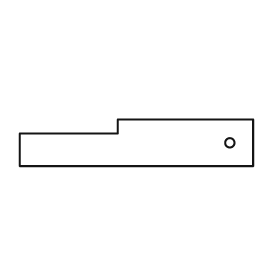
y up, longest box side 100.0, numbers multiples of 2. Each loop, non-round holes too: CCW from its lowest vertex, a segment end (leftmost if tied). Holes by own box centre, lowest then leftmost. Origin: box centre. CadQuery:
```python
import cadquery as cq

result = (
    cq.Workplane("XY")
    .moveTo(-50.0, -10.0)
    .lineTo(50.0, -10.0)
    .lineTo(50.0, 10.0)
    .lineTo(-8.0, 10.0)
    .lineTo(-8.0, 4.0)
    .lineTo(-50.0, 4.0)
    .close()
    .moveTo(40.0, 0.0)
    .circle(2.0)
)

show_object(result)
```